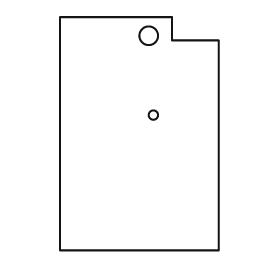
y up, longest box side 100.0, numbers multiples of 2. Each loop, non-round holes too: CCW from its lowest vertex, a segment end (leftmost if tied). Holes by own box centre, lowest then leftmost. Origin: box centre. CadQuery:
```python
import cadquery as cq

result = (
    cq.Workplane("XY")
    .moveTo(-34.0, -50.0)
    .lineTo(34.0, -50.0)
    .lineTo(34.0, 40.0)
    .lineTo(14.0, 40.0)
    .lineTo(14.0, 50.0)
    .lineTo(-34.0, 50.0)
    .close()
    .moveTo(6.0, 8.0)
    .circle(2.0)
    .moveTo(4.0, 42.0)
    .circle(4.0)
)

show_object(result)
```